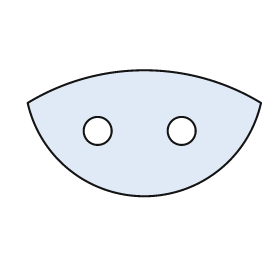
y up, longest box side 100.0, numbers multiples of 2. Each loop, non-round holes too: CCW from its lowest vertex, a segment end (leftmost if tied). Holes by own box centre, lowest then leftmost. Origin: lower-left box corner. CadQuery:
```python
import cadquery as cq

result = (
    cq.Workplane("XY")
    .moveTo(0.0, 40.0)
    .threePointArc((50.0, 0.0), (100.0, 40.0))
    .threePointArc((50.0, 54.0), (0.0, 40.0))
    .close()
    .moveTo(30.0, 28.0)
    .circle(6.0)
    .moveTo(66.0, 28.0)
    .circle(6.0)
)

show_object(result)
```